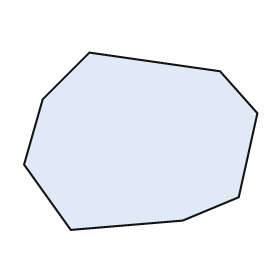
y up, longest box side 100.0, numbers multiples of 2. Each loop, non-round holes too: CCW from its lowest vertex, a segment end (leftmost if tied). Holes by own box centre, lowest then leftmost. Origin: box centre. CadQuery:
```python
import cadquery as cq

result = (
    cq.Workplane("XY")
    .moveTo(-30.0, -38.0)
    .lineTo(18.0, -34.0)
    .lineTo(42.0, -24.0)
    .lineTo(50.0, 12.0)
    .lineTo(34.0, 30.0)
    .lineTo(-22.0, 38.0)
    .lineTo(-42.0, 18.0)
    .lineTo(-50.0, -10.0)
    .close()
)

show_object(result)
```